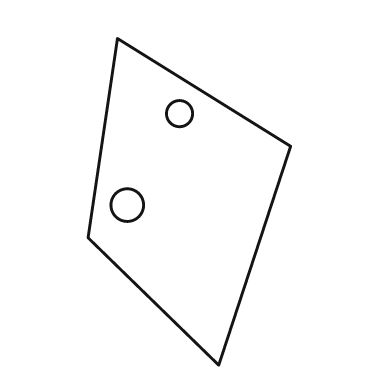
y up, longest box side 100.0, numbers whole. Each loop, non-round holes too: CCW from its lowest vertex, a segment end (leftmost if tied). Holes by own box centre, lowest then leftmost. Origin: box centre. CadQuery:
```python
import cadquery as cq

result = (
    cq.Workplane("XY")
    .moveTo(9.0, -50.0)
    .lineTo(31.0, 17.0)
    .lineTo(-22.0, 50.0)
    .lineTo(-31.0, -11.0)
    .close()
    .moveTo(-19.0, -1.0)
    .circle(5.0)
    .moveTo(-3.0, 27.0)
    .circle(4.0)
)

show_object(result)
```